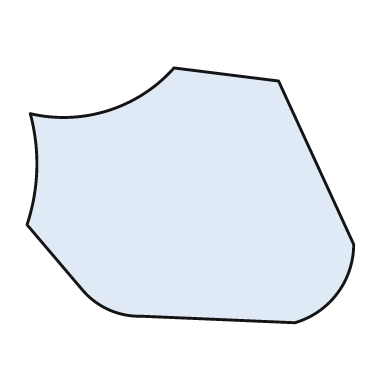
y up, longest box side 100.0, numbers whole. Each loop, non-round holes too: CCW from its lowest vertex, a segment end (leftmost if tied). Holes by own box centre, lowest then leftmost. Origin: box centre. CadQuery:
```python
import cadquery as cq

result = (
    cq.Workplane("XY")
    .moveTo(32.0, -39.0)
    .threePointArc((45.0, -30.0), (50.0, -15.0))
    .lineTo(27.0, 35.0)
    .lineTo(-5.0, 39.0)
    .threePointArc((-25.0, 26.0), (-49.0, 25.0))
    .threePointArc((-47.0, 8.0), (-50.0, -9.0))
    .lineTo(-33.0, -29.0)
    .threePointArc((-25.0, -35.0), (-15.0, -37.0))
    .close()
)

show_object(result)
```